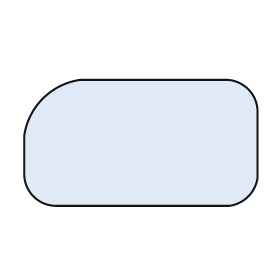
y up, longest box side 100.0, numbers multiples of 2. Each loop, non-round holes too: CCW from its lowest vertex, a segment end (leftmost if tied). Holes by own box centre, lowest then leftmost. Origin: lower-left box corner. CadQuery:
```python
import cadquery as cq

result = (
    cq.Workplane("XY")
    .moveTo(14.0, 0.0)
    .lineTo(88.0, 0.0)
    .threePointArc((96.0, 4.0), (100.0, 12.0))
    .lineTo(100.0, 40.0)
    .threePointArc((96.0, 50.0), (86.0, 54.0))
    .lineTo(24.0, 54.0)
    .threePointArc((8.0, 46.0), (0.0, 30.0))
    .lineTo(0.0, 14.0)
    .threePointArc((4.0, 4.0), (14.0, 0.0))
    .close()
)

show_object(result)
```